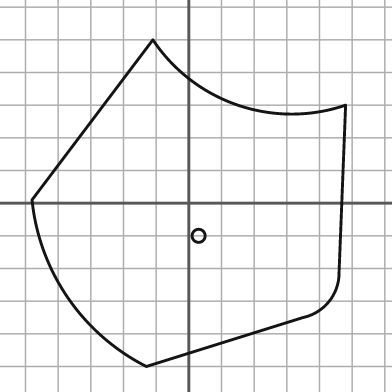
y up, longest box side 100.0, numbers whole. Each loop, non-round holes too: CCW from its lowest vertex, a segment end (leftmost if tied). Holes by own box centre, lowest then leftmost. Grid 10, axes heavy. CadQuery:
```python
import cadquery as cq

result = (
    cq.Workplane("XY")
    .moveTo(-13.0, -50.0)
    .lineTo(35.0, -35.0)
    .threePointArc((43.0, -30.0), (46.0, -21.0))
    .lineTo(48.0, 30.0)
    .threePointArc((15.0, 30.0), (-11.0, 50.0))
    .lineTo(-48.0, 1.0)
    .threePointArc((-37.0, -29.0), (-13.0, -50.0))
    .close()
    .moveTo(3.0, -10.0)
    .circle(2.0)
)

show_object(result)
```